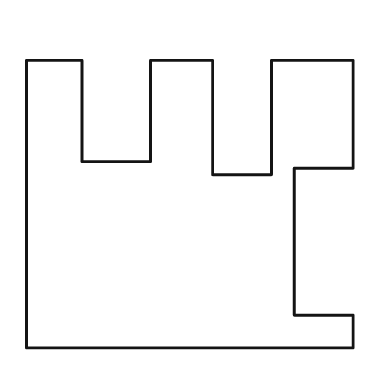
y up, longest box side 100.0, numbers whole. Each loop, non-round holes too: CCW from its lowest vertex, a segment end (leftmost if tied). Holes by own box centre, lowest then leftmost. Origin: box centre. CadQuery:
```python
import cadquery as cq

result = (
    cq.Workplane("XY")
    .moveTo(-50.0, -44.0)
    .lineTo(50.0, -44.0)
    .lineTo(50.0, -34.0)
    .lineTo(32.0, -34.0)
    .lineTo(32.0, 11.0)
    .lineTo(50.0, 11.0)
    .lineTo(50.0, 44.0)
    .lineTo(25.0, 44.0)
    .lineTo(25.0, 9.0)
    .lineTo(7.0, 9.0)
    .lineTo(7.0, 44.0)
    .lineTo(-12.0, 44.0)
    .lineTo(-12.0, 13.0)
    .lineTo(-33.0, 13.0)
    .lineTo(-33.0, 44.0)
    .lineTo(-50.0, 44.0)
    .close()
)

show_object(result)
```